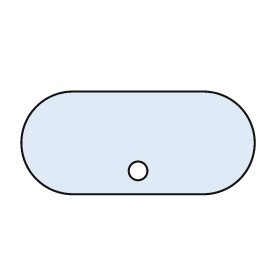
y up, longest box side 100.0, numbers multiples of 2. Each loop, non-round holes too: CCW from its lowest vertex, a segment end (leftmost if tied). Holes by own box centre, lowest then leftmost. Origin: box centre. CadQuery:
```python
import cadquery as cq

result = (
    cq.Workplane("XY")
    .moveTo(-28.0, -22.0)
    .lineTo(28.0, -22.0)
    .threePointArc((50.0, 0.0), (28.0, 22.0))
    .lineTo(-28.0, 22.0)
    .threePointArc((-50.0, 0.0), (-28.0, -22.0))
    .close()
    .moveTo(0.0, -12.0)
    .circle(4.0)
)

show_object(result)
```